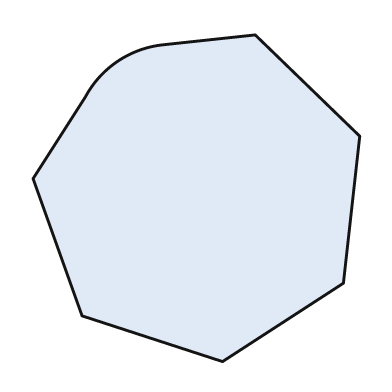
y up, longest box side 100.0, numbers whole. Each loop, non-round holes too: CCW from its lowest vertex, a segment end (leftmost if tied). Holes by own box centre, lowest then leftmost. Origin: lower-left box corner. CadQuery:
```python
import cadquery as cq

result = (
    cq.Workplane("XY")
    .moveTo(58.0, 0.0)
    .lineTo(95.0, 24.0)
    .lineTo(100.0, 69.0)
    .lineTo(68.0, 100.0)
    .lineTo(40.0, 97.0)
    .threePointArc((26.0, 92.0), (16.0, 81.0))
    .lineTo(0.0, 56.0)
    .lineTo(15.0, 14.0)
    .close()
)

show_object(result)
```